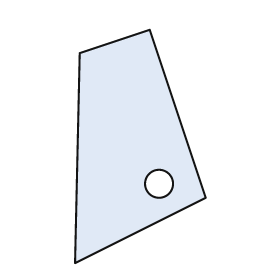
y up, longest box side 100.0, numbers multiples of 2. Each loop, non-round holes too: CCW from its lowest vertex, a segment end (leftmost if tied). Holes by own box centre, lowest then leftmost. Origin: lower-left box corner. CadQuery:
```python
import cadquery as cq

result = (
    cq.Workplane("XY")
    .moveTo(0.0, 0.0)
    .lineTo(56.0, 28.0)
    .lineTo(32.0, 100.0)
    .lineTo(2.0, 90.0)
    .close()
    .moveTo(36.0, 34.0)
    .circle(6.0)
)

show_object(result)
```